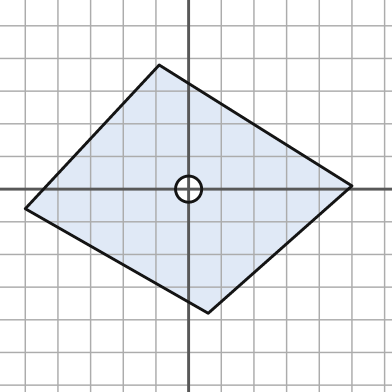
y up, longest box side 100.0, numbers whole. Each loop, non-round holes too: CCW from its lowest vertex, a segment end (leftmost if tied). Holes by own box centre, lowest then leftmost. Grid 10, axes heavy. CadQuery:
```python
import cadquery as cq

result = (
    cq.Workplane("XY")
    .moveTo(6.0, -38.0)
    .lineTo(50.0, 1.0)
    .lineTo(-9.0, 38.0)
    .lineTo(-50.0, -6.0)
    .close()
    .moveTo(0.0, 0.0)
    .circle(4.0)
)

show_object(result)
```